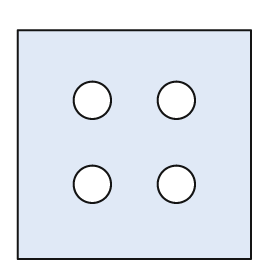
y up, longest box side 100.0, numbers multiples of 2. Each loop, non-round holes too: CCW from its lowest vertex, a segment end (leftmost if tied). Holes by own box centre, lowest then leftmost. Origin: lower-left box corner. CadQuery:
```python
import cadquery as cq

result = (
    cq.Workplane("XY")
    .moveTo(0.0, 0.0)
    .lineTo(100.0, 0.0)
    .lineTo(100.0, 98.0)
    .lineTo(0.0, 98.0)
    .close()
    .moveTo(32.0, 32.0)
    .circle(8.0)
    .moveTo(68.0, 32.0)
    .circle(8.0)
    .moveTo(32.0, 68.0)
    .circle(8.0)
    .moveTo(68.0, 68.0)
    .circle(8.0)
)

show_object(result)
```